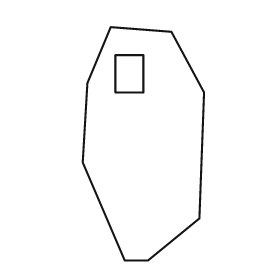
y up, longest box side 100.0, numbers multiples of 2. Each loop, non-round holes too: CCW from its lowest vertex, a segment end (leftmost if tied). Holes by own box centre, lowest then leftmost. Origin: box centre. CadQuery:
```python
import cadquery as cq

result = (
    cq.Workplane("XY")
    .moveTo(-8.0, -50.0)
    .lineTo(2.0, -50.0)
    .lineTo(24.0, -32.0)
    .lineTo(26.0, 22.0)
    .lineTo(12.0, 48.0)
    .lineTo(-14.0, 50.0)
    .lineTo(-24.0, 26.0)
    .lineTo(-26.0, -8.0)
    .close()
    .moveTo(-12.0, 22.0)
    .lineTo(0.0, 22.0)
    .lineTo(0.0, 38.0)
    .lineTo(-12.0, 38.0)
    .close()
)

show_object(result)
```